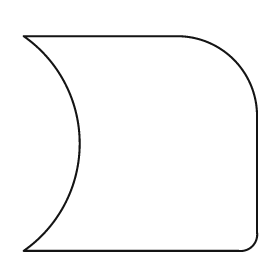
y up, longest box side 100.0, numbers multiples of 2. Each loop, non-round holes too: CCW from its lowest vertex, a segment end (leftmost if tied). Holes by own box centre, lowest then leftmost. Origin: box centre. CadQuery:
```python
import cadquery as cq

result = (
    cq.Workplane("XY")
    .moveTo(-50.0, -46.0)
    .lineTo(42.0, -46.0)
    .threePointArc((48.0, -44.0), (50.0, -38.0))
    .lineTo(50.0, 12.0)
    .threePointArc((40.0, 36.0), (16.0, 46.0))
    .lineTo(-50.0, 46.0)
    .threePointArc((-26.0, 0.0), (-50.0, -46.0))
    .close()
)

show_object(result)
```